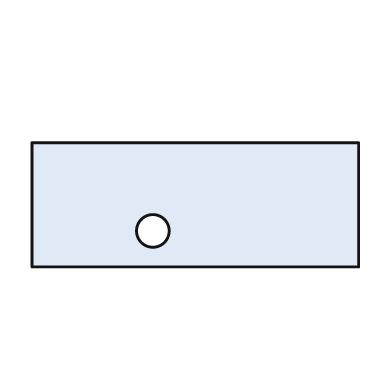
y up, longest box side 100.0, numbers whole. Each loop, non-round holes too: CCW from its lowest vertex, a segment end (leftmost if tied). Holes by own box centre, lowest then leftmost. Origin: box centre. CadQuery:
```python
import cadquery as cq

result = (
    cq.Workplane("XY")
    .moveTo(-50.0, -19.0)
    .lineTo(50.0, -19.0)
    .lineTo(50.0, 19.0)
    .lineTo(-50.0, 19.0)
    .close()
    .moveTo(-13.0, -8.0)
    .circle(5.0)
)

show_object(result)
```